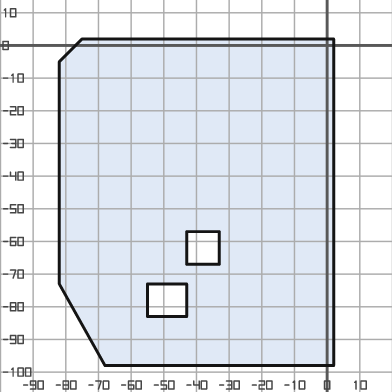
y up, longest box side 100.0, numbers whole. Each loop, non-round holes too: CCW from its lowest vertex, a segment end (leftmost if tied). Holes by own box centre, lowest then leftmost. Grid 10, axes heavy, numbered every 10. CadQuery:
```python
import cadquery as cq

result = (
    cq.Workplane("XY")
    .moveTo(-68.0, -98.0)
    .lineTo(2.0, -98.0)
    .lineTo(2.0, 2.0)
    .lineTo(-75.0, 2.0)
    .lineTo(-82.0, -5.0)
    .lineTo(-82.0, -73.0)
    .close()
    .moveTo(-55.0, -83.0)
    .lineTo(-43.0, -83.0)
    .lineTo(-43.0, -73.0)
    .lineTo(-55.0, -73.0)
    .close()
    .moveTo(-43.0, -67.0)
    .lineTo(-33.0, -67.0)
    .lineTo(-33.0, -57.0)
    .lineTo(-43.0, -57.0)
    .close()
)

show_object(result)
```